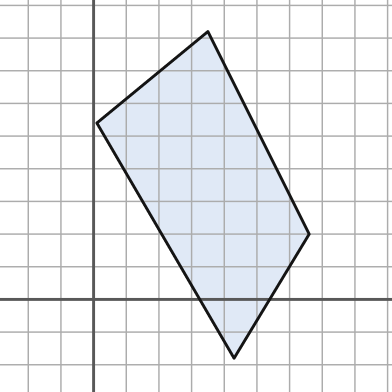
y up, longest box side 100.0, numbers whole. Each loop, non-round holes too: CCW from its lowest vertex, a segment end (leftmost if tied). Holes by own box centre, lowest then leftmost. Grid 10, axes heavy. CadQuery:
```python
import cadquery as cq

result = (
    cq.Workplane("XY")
    .moveTo(43.0, -18.0)
    .lineTo(66.0, 20.0)
    .lineTo(35.0, 82.0)
    .lineTo(1.0, 54.0)
    .close()
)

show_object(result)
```